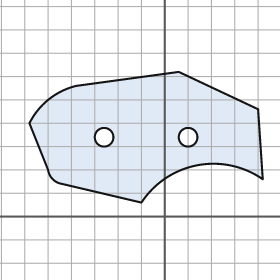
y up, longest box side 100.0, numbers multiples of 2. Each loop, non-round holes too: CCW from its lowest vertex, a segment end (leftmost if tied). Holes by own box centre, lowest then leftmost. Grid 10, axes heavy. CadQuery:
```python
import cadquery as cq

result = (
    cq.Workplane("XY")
    .moveTo(-10.0, 6.0)
    .threePointArc((14.0, 22.0), (42.0, 16.0))
    .lineTo(40.0, 46.0)
    .lineTo(6.0, 62.0)
    .lineTo(-38.0, 56.0)
    .threePointArc((-50.0, 50.0), (-58.0, 40.0))
    .lineTo(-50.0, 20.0)
    .threePointArc((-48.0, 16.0), (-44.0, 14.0))
    .close()
    .moveTo(-26.0, 34.0)
    .circle(4.0)
    .moveTo(10.0, 34.0)
    .circle(4.0)
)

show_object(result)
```